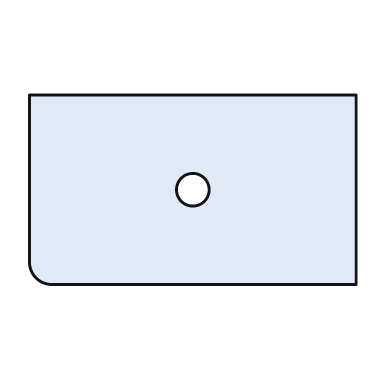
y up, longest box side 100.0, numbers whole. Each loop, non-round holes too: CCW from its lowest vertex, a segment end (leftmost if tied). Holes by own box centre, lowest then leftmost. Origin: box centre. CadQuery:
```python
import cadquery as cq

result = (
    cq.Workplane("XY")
    .moveTo(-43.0, -29.0)
    .lineTo(50.0, -29.0)
    .lineTo(50.0, 29.0)
    .lineTo(-50.0, 29.0)
    .lineTo(-50.0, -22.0)
    .threePointArc((-48.0, -27.0), (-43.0, -29.0))
    .close()
    .moveTo(0.0, 0.0)
    .circle(5.0)
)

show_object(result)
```